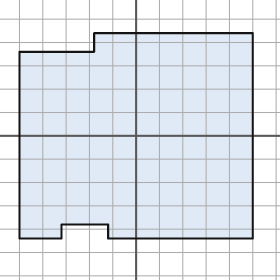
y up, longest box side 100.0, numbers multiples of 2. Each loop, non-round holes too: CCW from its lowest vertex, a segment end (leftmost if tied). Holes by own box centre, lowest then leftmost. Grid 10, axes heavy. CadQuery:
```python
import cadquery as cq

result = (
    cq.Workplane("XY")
    .moveTo(-50.0, -44.0)
    .lineTo(-32.0, -44.0)
    .lineTo(-32.0, -38.0)
    .lineTo(-12.0, -38.0)
    .lineTo(-12.0, -44.0)
    .lineTo(50.0, -44.0)
    .lineTo(50.0, 44.0)
    .lineTo(-18.0, 44.0)
    .lineTo(-18.0, 36.0)
    .lineTo(-50.0, 36.0)
    .close()
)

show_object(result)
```